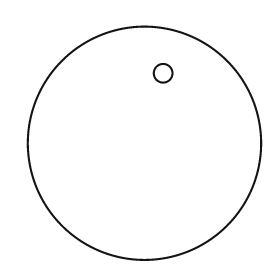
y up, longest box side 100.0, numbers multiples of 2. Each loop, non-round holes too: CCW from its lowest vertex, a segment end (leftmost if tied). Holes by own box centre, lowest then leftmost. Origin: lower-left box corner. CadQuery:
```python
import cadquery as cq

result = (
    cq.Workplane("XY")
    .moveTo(50.0, 50.0)
    .circle(50.0)
    .moveTo(58.0, 80.0)
    .circle(4.0)
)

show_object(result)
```